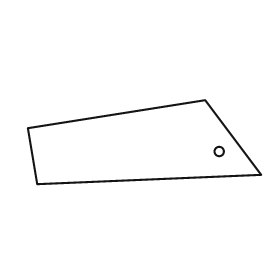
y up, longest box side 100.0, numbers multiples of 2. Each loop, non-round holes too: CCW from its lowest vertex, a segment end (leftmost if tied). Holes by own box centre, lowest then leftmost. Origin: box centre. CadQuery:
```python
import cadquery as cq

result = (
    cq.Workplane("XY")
    .moveTo(-46.0, -18.0)
    .lineTo(50.0, -14.0)
    .lineTo(26.0, 18.0)
    .lineTo(-50.0, 6.0)
    .close()
    .moveTo(32.0, -4.0)
    .circle(2.0)
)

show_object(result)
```